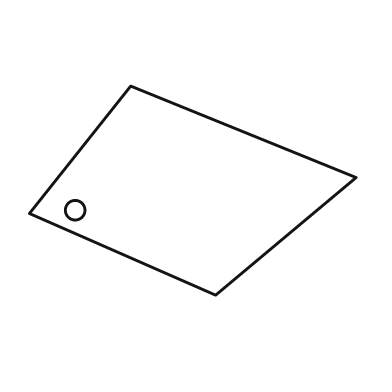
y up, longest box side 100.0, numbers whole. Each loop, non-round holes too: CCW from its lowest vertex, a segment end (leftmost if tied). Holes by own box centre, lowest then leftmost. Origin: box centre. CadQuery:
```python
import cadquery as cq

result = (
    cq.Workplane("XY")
    .moveTo(7.0, -32.0)
    .lineTo(50.0, 4.0)
    .lineTo(-19.0, 32.0)
    .lineTo(-50.0, -7.0)
    .close()
    .moveTo(-36.0, -6.0)
    .circle(3.0)
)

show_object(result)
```